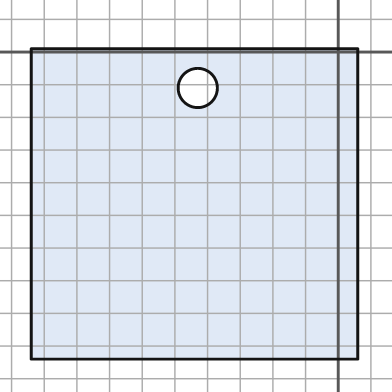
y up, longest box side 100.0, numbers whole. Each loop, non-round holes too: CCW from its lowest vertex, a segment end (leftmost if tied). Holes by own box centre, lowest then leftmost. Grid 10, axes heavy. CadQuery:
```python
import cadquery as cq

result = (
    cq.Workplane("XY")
    .moveTo(-94.0, -94.0)
    .lineTo(6.0, -94.0)
    .lineTo(6.0, 1.0)
    .lineTo(-94.0, 1.0)
    .close()
    .moveTo(-43.0, -11.0)
    .circle(6.0)
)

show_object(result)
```